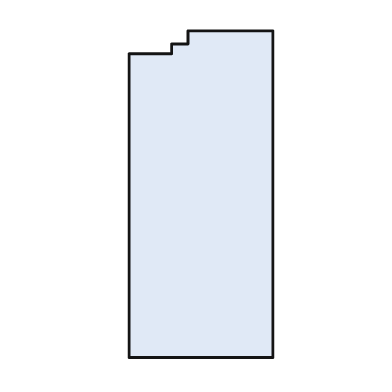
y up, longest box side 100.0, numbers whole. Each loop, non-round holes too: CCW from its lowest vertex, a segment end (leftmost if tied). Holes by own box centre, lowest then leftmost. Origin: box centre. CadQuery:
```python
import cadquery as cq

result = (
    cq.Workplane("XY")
    .moveTo(-22.0, -50.0)
    .lineTo(22.0, -50.0)
    .lineTo(22.0, 50.0)
    .lineTo(-4.0, 50.0)
    .lineTo(-4.0, 46.0)
    .lineTo(-9.0, 46.0)
    .lineTo(-9.0, 43.0)
    .lineTo(-22.0, 43.0)
    .close()
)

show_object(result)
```